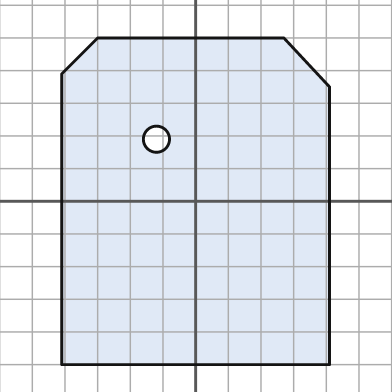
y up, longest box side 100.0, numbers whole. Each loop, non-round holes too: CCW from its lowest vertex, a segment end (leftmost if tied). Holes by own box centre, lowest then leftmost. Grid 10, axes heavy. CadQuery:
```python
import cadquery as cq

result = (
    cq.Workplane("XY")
    .moveTo(-41.0, -50.0)
    .lineTo(41.0, -50.0)
    .lineTo(41.0, 35.0)
    .lineTo(27.0, 50.0)
    .lineTo(-30.0, 50.0)
    .lineTo(-41.0, 39.0)
    .close()
    .moveTo(-12.0, 19.0)
    .circle(4.0)
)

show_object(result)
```